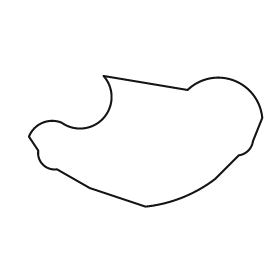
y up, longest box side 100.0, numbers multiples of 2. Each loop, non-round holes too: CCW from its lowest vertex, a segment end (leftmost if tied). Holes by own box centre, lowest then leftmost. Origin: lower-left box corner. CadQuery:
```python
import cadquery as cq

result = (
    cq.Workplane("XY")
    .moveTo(50.0, 0.0)
    .threePointArc((66.0, 4.0), (80.0, 12.0))
    .lineTo(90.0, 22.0)
    .threePointArc((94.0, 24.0), (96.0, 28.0))
    .lineTo(100.0, 38.0)
    .threePointArc((88.0, 54.0), (68.0, 50.0))
    .lineTo(32.0, 56.0)
    .threePointArc((32.0, 38.0), (14.0, 36.0))
    .threePointArc((6.0, 36.0), (0.0, 30.0))
    .lineTo(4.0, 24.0)
    .threePointArc((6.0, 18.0), (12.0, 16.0))
    .lineTo(26.0, 8.0)
    .close()
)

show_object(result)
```